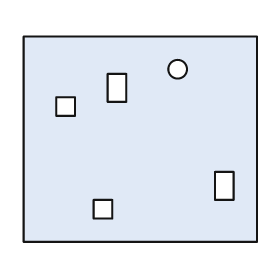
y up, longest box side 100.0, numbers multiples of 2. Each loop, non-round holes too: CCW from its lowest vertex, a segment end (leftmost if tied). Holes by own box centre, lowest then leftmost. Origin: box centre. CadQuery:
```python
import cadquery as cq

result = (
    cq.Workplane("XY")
    .moveTo(-50.0, -44.0)
    .lineTo(50.0, -44.0)
    .lineTo(50.0, 44.0)
    .lineTo(-50.0, 44.0)
    .close()
    .moveTo(-20.0, -34.0)
    .lineTo(-12.0, -34.0)
    .lineTo(-12.0, -26.0)
    .lineTo(-20.0, -26.0)
    .close()
    .moveTo(32.0, -26.0)
    .lineTo(40.0, -26.0)
    .lineTo(40.0, -14.0)
    .lineTo(32.0, -14.0)
    .close()
    .moveTo(-36.0, 10.0)
    .lineTo(-28.0, 10.0)
    .lineTo(-28.0, 18.0)
    .lineTo(-36.0, 18.0)
    .close()
    .moveTo(-14.0, 16.0)
    .lineTo(-6.0, 16.0)
    .lineTo(-6.0, 28.0)
    .lineTo(-14.0, 28.0)
    .close()
    .moveTo(16.0, 30.0)
    .circle(4.0)
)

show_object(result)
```